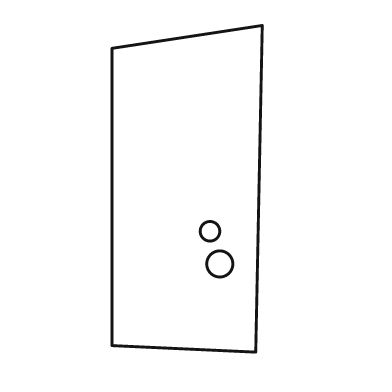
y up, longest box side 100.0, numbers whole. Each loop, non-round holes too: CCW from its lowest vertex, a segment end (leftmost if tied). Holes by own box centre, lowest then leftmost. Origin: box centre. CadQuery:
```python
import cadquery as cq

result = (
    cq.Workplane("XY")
    .moveTo(21.0, -50.0)
    .lineTo(23.0, 50.0)
    .lineTo(-23.0, 43.0)
    .lineTo(-23.0, -48.0)
    .close()
    .moveTo(10.0, -23.0)
    .circle(4.0)
    .moveTo(7.0, -13.0)
    .circle(3.0)
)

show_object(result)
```